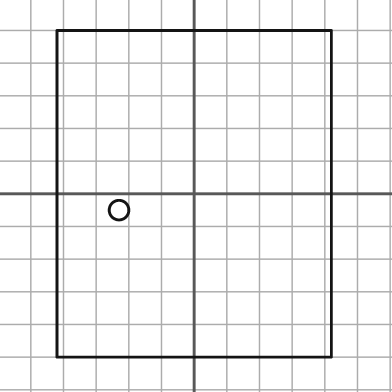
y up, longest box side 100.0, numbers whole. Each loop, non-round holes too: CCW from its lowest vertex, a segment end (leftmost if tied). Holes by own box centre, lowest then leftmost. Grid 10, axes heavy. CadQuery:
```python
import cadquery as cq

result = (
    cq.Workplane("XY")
    .moveTo(-42.0, -50.0)
    .lineTo(42.0, -50.0)
    .lineTo(42.0, 50.0)
    .lineTo(-42.0, 50.0)
    .close()
    .moveTo(-23.0, -5.0)
    .circle(3.0)
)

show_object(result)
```